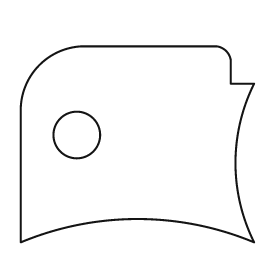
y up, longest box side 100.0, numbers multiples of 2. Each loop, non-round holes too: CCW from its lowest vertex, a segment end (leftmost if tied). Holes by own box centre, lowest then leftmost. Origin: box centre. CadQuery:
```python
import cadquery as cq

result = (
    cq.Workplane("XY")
    .moveTo(-50.0, -42.0)
    .threePointArc((0.0, -32.0), (50.0, -42.0))
    .threePointArc((42.0, -8.0), (50.0, 26.0))
    .lineTo(40.0, 26.0)
    .lineTo(40.0, 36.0)
    .threePointArc((38.0, 40.0), (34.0, 42.0))
    .lineTo(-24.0, 42.0)
    .threePointArc((-42.0, 34.0), (-50.0, 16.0))
    .close()
    .moveTo(-26.0, 4.0)
    .circle(10.0)
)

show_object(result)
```